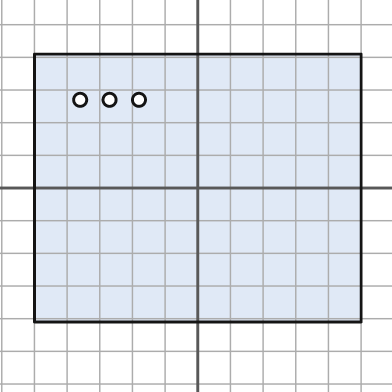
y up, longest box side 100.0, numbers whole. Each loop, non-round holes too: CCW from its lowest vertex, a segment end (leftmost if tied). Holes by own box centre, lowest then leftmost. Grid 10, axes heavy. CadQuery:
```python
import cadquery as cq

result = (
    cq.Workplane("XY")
    .moveTo(-50.0, -41.0)
    .lineTo(50.0, -41.0)
    .lineTo(50.0, 41.0)
    .lineTo(-50.0, 41.0)
    .close()
    .moveTo(-36.0, 27.0)
    .circle(2.0)
    .moveTo(-27.0, 27.0)
    .circle(2.0)
    .moveTo(-18.0, 27.0)
    .circle(2.0)
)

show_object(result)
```